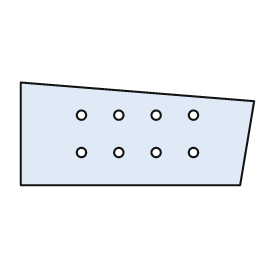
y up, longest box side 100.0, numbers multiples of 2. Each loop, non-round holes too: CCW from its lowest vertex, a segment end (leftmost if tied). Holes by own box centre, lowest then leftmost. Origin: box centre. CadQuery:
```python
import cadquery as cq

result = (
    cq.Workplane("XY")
    .moveTo(-50.0, -22.0)
    .lineTo(44.0, -22.0)
    .lineTo(50.0, 14.0)
    .lineTo(-50.0, 22.0)
    .close()
    .moveTo(-24.0, -8.0)
    .circle(2.0)
    .moveTo(-8.0, -8.0)
    .circle(2.0)
    .moveTo(8.0, -8.0)
    .circle(2.0)
    .moveTo(24.0, -8.0)
    .circle(2.0)
    .moveTo(-24.0, 8.0)
    .circle(2.0)
    .moveTo(-8.0, 8.0)
    .circle(2.0)
    .moveTo(8.0, 8.0)
    .circle(2.0)
    .moveTo(24.0, 8.0)
    .circle(2.0)
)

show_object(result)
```